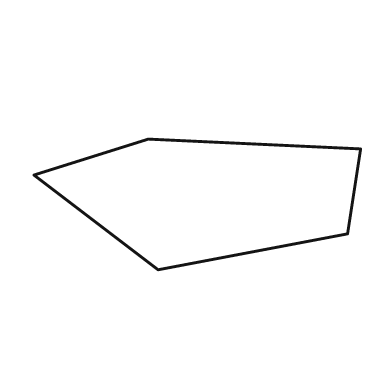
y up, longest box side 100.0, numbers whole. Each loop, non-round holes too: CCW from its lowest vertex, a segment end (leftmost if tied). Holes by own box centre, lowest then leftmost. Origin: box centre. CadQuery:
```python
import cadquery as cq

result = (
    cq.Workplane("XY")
    .moveTo(-12.0, -20.0)
    .lineTo(46.0, -9.0)
    .lineTo(50.0, 17.0)
    .lineTo(-15.0, 20.0)
    .lineTo(-50.0, 9.0)
    .close()
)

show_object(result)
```